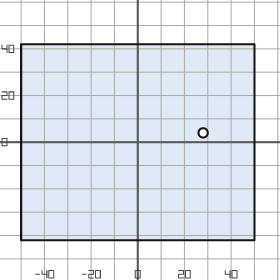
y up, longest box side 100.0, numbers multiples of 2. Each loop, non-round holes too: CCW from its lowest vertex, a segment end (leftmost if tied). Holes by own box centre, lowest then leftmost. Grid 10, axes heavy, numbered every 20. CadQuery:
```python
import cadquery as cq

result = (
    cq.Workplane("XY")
    .moveTo(-50.0, -42.0)
    .lineTo(50.0, -42.0)
    .lineTo(50.0, 42.0)
    .lineTo(-50.0, 42.0)
    .close()
    .moveTo(28.0, 4.0)
    .circle(2.0)
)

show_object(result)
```